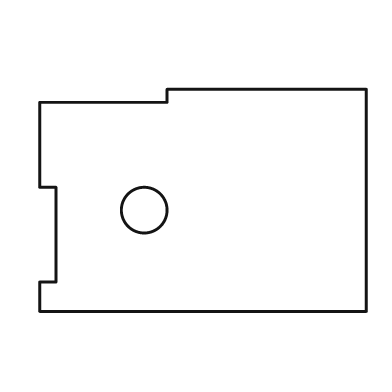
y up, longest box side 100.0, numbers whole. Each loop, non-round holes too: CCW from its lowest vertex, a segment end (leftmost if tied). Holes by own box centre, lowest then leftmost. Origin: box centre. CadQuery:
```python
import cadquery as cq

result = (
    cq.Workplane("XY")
    .moveTo(-50.0, -34.0)
    .lineTo(50.0, -34.0)
    .lineTo(50.0, 34.0)
    .lineTo(-11.0, 34.0)
    .lineTo(-11.0, 30.0)
    .lineTo(-50.0, 30.0)
    .lineTo(-50.0, 4.0)
    .lineTo(-45.0, 4.0)
    .lineTo(-45.0, -25.0)
    .lineTo(-50.0, -25.0)
    .close()
    .moveTo(-18.0, -3.0)
    .circle(7.0)
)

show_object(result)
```